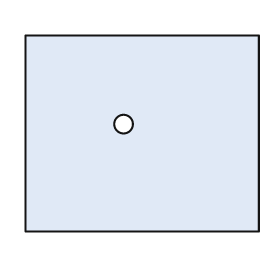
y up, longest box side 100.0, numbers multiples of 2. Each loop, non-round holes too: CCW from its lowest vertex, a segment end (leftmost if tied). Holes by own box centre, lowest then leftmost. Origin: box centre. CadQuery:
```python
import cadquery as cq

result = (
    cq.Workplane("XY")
    .moveTo(-50.0, -42.0)
    .lineTo(50.0, -42.0)
    .lineTo(50.0, 42.0)
    .lineTo(-50.0, 42.0)
    .close()
    .moveTo(-8.0, 4.0)
    .circle(4.0)
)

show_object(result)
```